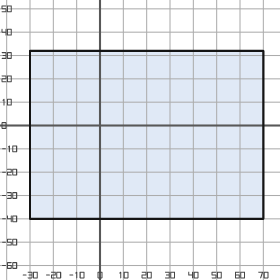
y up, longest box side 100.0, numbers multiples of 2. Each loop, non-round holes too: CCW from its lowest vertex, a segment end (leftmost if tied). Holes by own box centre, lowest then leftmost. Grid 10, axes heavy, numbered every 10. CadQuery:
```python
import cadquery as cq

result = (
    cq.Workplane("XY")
    .moveTo(-30.0, -40.0)
    .lineTo(70.0, -40.0)
    .lineTo(70.0, 32.0)
    .lineTo(-30.0, 32.0)
    .close()
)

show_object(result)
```